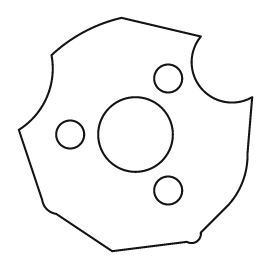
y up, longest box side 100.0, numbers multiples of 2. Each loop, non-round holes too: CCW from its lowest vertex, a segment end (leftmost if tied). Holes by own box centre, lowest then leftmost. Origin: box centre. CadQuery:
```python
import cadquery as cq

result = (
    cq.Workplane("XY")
    .moveTo(-10.0, -50.0)
    .lineTo(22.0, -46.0)
    .threePointArc((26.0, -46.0), (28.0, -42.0))
    .lineTo(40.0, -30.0)
    .threePointArc((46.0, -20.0), (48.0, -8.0))
    .lineTo(50.0, 16.0)
    .threePointArc((28.0, 20.0), (28.0, 42.0))
    .lineTo(-6.0, 50.0)
    .threePointArc((-22.0, 44.0), (-36.0, 34.0))
    .threePointArc((-38.0, 16.0), (-50.0, 2.0))
    .lineTo(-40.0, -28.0)
    .threePointArc((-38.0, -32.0), (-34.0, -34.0))
    .close()
    .moveTo(14.0, -24.0)
    .circle(6.0)
    .moveTo(-28.0, 0.0)
    .circle(6.0)
    .moveTo(0.0, 0.0)
    .circle(16.0)
    .moveTo(14.0, 24.0)
    .circle(6.0)
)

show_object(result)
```